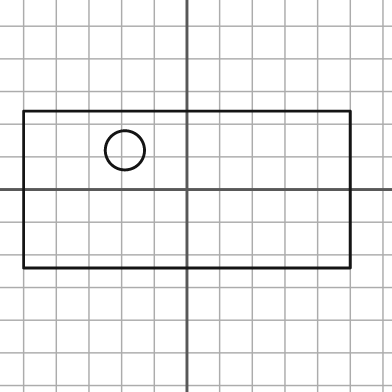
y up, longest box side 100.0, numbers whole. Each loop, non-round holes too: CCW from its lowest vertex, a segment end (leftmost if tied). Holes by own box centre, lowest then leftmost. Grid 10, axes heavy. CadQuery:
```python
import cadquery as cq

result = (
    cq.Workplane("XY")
    .moveTo(-50.0, -24.0)
    .lineTo(50.0, -24.0)
    .lineTo(50.0, 24.0)
    .lineTo(-50.0, 24.0)
    .close()
    .moveTo(-19.0, 12.0)
    .circle(6.0)
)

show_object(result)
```